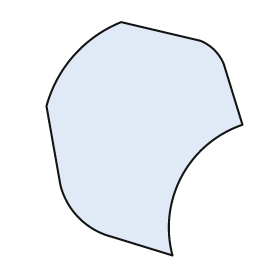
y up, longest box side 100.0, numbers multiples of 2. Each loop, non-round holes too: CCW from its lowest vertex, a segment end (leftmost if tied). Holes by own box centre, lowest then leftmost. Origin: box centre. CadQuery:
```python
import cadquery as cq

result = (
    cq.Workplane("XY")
    .moveTo(12.0, -50.0)
    .threePointArc((16.0, -16.0), (42.0, 6.0))
    .lineTo(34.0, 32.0)
    .threePointArc((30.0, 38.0), (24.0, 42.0))
    .lineTo(-10.0, 50.0)
    .threePointArc((-30.0, 36.0), (-42.0, 14.0))
    .lineTo(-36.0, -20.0)
    .threePointArc((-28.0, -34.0), (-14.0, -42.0))
    .close()
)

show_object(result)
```